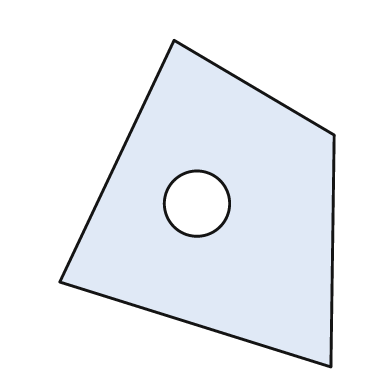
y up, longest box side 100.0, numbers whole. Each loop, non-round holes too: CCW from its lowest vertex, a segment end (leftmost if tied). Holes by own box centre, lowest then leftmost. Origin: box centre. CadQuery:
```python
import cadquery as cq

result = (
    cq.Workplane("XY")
    .moveTo(41.0, -50.0)
    .lineTo(42.0, 21.0)
    .lineTo(-7.0, 50.0)
    .lineTo(-42.0, -24.0)
    .close()
    .moveTo(0.0, 0.0)
    .circle(10.0)
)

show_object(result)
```